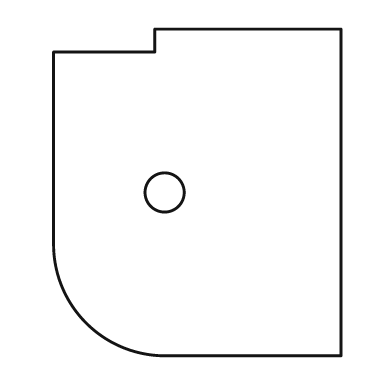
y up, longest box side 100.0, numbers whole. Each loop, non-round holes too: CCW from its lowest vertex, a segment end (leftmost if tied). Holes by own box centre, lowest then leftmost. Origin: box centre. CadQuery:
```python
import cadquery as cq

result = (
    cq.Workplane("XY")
    .moveTo(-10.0, -50.0)
    .lineTo(44.0, -50.0)
    .lineTo(44.0, 50.0)
    .lineTo(-13.0, 50.0)
    .lineTo(-13.0, 43.0)
    .lineTo(-44.0, 43.0)
    .lineTo(-44.0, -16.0)
    .threePointArc((-34.0, -40.0), (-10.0, -50.0))
    .close()
    .moveTo(-10.0, 0.0)
    .circle(6.0)
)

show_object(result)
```